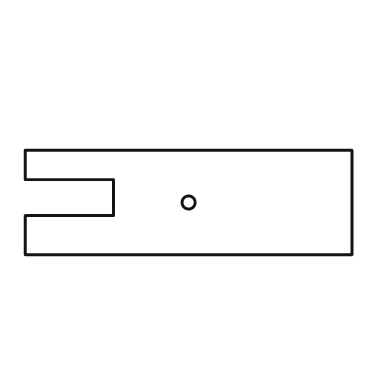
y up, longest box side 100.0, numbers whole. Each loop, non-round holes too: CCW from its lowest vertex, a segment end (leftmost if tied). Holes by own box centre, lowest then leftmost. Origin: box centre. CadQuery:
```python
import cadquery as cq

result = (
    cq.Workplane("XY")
    .moveTo(-50.0, -16.0)
    .lineTo(50.0, -16.0)
    .lineTo(50.0, 16.0)
    .lineTo(-50.0, 16.0)
    .lineTo(-50.0, 7.0)
    .lineTo(-23.0, 7.0)
    .lineTo(-23.0, -4.0)
    .lineTo(-50.0, -4.0)
    .close()
    .moveTo(0.0, 0.0)
    .circle(2.0)
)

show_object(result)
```